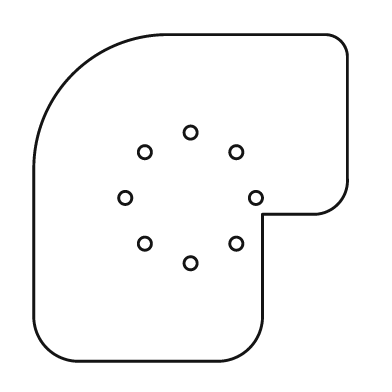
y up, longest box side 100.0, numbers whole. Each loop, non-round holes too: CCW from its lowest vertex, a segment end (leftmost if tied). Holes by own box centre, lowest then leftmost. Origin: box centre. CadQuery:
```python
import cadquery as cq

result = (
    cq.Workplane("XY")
    .moveTo(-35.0, -50.0)
    .lineTo(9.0, -50.0)
    .threePointArc((18.0, -46.0), (22.0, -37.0))
    .lineTo(22.0, -5.0)
    .lineTo(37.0, -5.0)
    .threePointArc((45.0, -2.0), (48.0, 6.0))
    .lineTo(48.0, 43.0)
    .threePointArc((46.0, 48.0), (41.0, 50.0))
    .lineTo(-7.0, 50.0)
    .threePointArc((-36.0, 38.0), (-48.0, 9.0))
    .lineTo(-48.0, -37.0)
    .threePointArc((-44.0, -46.0), (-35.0, -50.0))
    .close()
    .moveTo(0.0, -20.0)
    .circle(2.0)
    .moveTo(-14.0, -14.0)
    .circle(2.0)
    .moveTo(14.0, -14.0)
    .circle(2.0)
    .moveTo(-20.0, 0.0)
    .circle(2.0)
    .moveTo(20.0, 0.0)
    .circle(2.0)
    .moveTo(-14.0, 14.0)
    .circle(2.0)
    .moveTo(14.0, 14.0)
    .circle(2.0)
    .moveTo(0.0, 20.0)
    .circle(2.0)
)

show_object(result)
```